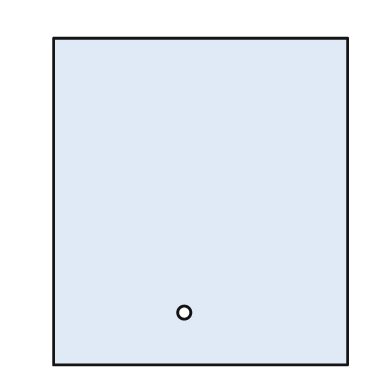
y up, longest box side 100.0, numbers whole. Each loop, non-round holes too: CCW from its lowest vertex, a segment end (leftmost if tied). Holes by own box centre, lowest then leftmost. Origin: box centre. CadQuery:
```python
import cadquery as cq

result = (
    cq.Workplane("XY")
    .moveTo(-45.0, -50.0)
    .lineTo(45.0, -50.0)
    .lineTo(45.0, 50.0)
    .lineTo(-45.0, 50.0)
    .close()
    .moveTo(-5.0, -34.0)
    .circle(2.0)
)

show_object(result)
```